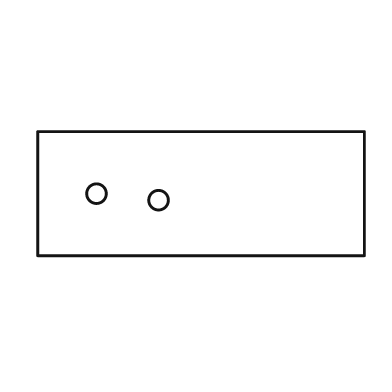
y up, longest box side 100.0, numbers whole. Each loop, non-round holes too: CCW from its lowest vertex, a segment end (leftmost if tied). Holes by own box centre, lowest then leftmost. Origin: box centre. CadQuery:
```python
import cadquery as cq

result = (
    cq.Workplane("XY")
    .moveTo(-50.0, -19.0)
    .lineTo(50.0, -19.0)
    .lineTo(50.0, 19.0)
    .lineTo(-50.0, 19.0)
    .close()
    .moveTo(-13.0, -2.0)
    .circle(3.0)
    .moveTo(-32.0, 0.0)
    .circle(3.0)
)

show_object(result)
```